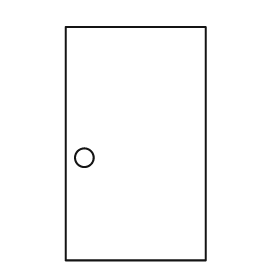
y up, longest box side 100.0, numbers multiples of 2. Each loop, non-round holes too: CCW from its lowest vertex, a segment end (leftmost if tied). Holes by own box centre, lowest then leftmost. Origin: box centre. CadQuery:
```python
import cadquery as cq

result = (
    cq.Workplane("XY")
    .moveTo(-30.0, -50.0)
    .lineTo(30.0, -50.0)
    .lineTo(30.0, 50.0)
    .lineTo(-30.0, 50.0)
    .close()
    .moveTo(-22.0, -6.0)
    .circle(4.0)
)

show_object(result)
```